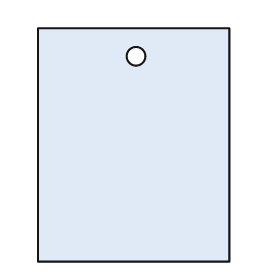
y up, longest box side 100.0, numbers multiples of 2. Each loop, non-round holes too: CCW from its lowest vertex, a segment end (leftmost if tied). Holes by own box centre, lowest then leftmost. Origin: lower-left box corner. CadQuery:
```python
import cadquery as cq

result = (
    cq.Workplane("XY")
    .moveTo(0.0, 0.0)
    .lineTo(82.0, 0.0)
    .lineTo(82.0, 100.0)
    .lineTo(0.0, 100.0)
    .close()
    .moveTo(42.0, 88.0)
    .circle(4.0)
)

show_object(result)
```